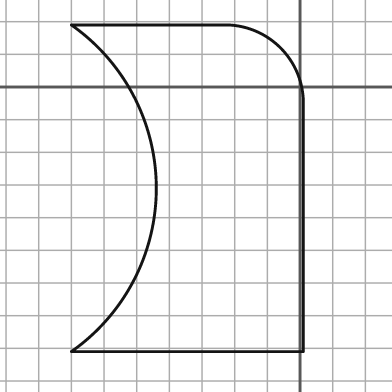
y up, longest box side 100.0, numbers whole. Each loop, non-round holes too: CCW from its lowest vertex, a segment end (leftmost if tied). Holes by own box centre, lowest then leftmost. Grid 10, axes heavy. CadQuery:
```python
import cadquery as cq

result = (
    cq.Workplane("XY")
    .moveTo(-70.0, -81.0)
    .lineTo(1.0, -81.0)
    .lineTo(1.0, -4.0)
    .threePointArc((-6.0, 12.0), (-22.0, 19.0))
    .lineTo(-70.0, 19.0)
    .threePointArc((-44.0, -31.0), (-70.0, -81.0))
    .close()
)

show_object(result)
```